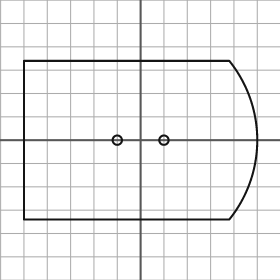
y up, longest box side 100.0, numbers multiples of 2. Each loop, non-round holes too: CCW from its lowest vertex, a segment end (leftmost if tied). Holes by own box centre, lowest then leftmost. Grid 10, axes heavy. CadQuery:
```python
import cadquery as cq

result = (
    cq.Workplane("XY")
    .moveTo(-50.0, -34.0)
    .lineTo(38.0, -34.0)
    .threePointArc((50.0, 0.0), (38.0, 34.0))
    .lineTo(-50.0, 34.0)
    .close()
    .moveTo(-10.0, 0.0)
    .circle(2.0)
    .moveTo(10.0, 0.0)
    .circle(2.0)
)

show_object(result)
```